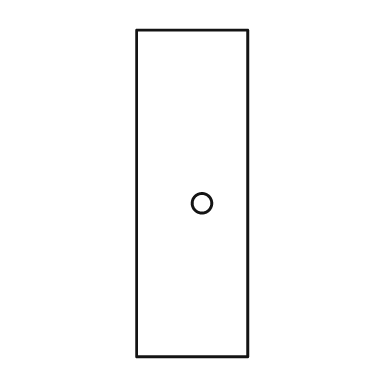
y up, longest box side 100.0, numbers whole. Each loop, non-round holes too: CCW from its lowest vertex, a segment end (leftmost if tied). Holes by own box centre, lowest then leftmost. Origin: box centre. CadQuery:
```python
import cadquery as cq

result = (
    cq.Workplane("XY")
    .moveTo(-17.0, -50.0)
    .lineTo(17.0, -50.0)
    .lineTo(17.0, 50.0)
    .lineTo(-17.0, 50.0)
    .close()
    .moveTo(3.0, -3.0)
    .circle(3.0)
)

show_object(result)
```